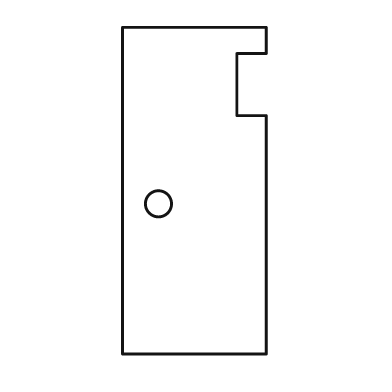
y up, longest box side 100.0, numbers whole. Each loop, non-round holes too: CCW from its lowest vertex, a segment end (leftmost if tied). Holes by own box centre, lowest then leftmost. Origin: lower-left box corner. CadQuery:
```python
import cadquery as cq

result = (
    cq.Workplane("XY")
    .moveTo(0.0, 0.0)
    .lineTo(44.0, 0.0)
    .lineTo(44.0, 73.0)
    .lineTo(35.0, 73.0)
    .lineTo(35.0, 92.0)
    .lineTo(44.0, 92.0)
    .lineTo(44.0, 100.0)
    .lineTo(0.0, 100.0)
    .close()
    .moveTo(11.0, 46.0)
    .circle(4.0)
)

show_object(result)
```